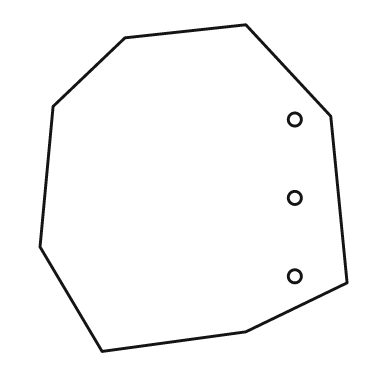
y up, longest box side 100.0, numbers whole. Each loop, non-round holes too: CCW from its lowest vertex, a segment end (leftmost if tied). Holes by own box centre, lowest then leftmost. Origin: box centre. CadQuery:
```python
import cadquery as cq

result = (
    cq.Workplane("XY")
    .moveTo(-28.0, -50.0)
    .lineTo(16.0, -44.0)
    .lineTo(47.0, -29.0)
    .lineTo(42.0, 22.0)
    .lineTo(16.0, 50.0)
    .lineTo(-21.0, 46.0)
    .lineTo(-43.0, 25.0)
    .lineTo(-47.0, -18.0)
    .close()
    .moveTo(31.0, -27.0)
    .circle(2.0)
    .moveTo(31.0, -3.0)
    .circle(2.0)
    .moveTo(31.0, 21.0)
    .circle(2.0)
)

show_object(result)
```